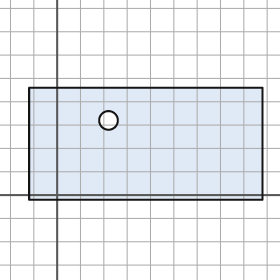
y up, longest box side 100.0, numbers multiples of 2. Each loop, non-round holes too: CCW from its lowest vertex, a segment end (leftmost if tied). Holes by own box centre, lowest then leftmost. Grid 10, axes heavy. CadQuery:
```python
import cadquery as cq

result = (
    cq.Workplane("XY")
    .moveTo(-12.0, -2.0)
    .lineTo(88.0, -2.0)
    .lineTo(88.0, 46.0)
    .lineTo(-12.0, 46.0)
    .close()
    .moveTo(22.0, 32.0)
    .circle(4.0)
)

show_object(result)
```